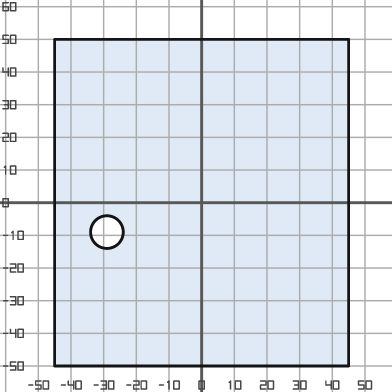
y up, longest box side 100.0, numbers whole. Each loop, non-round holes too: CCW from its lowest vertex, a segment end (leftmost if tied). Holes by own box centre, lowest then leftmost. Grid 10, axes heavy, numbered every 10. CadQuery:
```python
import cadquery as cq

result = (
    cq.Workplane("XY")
    .moveTo(-45.0, -50.0)
    .lineTo(45.0, -50.0)
    .lineTo(45.0, 50.0)
    .lineTo(-45.0, 50.0)
    .close()
    .moveTo(-29.0, -9.0)
    .circle(5.0)
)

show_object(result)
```